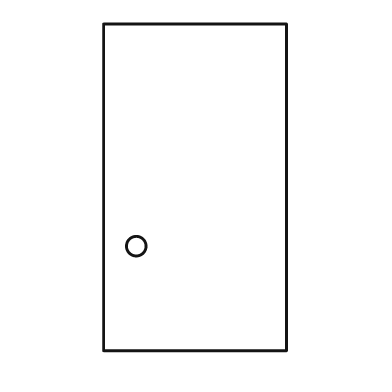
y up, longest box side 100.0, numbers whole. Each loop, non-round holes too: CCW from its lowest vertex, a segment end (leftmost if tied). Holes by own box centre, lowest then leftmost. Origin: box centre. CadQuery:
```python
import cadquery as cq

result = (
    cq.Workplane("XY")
    .moveTo(-28.0, -50.0)
    .lineTo(28.0, -50.0)
    .lineTo(28.0, 50.0)
    .lineTo(-28.0, 50.0)
    .close()
    .moveTo(-18.0, -18.0)
    .circle(3.0)
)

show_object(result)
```